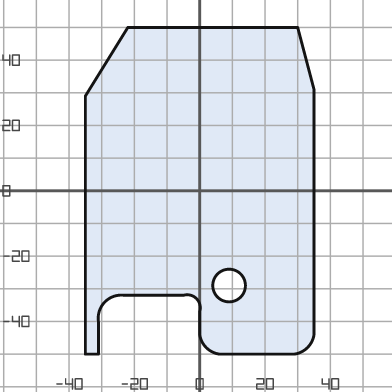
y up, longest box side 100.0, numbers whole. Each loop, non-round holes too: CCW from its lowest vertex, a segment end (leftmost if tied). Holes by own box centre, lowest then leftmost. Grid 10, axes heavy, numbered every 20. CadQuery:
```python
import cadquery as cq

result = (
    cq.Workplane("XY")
    .moveTo(-35.0, -50.0)
    .lineTo(-31.0, -50.0)
    .lineTo(-31.0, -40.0)
    .threePointArc((-29.0, -34.0), (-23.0, -32.0))
    .lineTo(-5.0, -32.0)
    .threePointArc((-1.0, -33.0), (0.0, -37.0))
    .lineTo(0.0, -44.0)
    .threePointArc((2.0, -48.0), (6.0, -50.0))
    .lineTo(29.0, -50.0)
    .threePointArc((33.0, -48.0), (35.0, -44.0))
    .lineTo(35.0, 31.0)
    .lineTo(30.0, 50.0)
    .lineTo(-22.0, 50.0)
    .lineTo(-35.0, 29.0)
    .close()
    .moveTo(9.0, -29.0)
    .circle(5.0)
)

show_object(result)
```